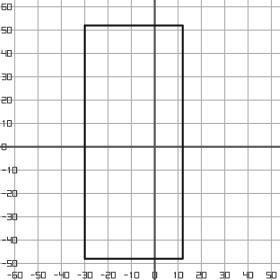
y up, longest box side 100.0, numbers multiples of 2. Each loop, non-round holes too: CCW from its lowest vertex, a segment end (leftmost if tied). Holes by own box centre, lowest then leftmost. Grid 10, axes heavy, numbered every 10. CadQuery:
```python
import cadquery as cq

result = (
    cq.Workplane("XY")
    .moveTo(-30.0, -48.0)
    .lineTo(12.0, -48.0)
    .lineTo(12.0, 52.0)
    .lineTo(-30.0, 52.0)
    .close()
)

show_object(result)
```